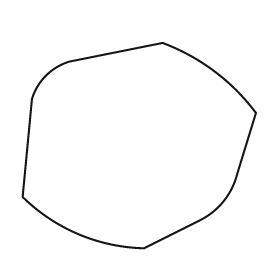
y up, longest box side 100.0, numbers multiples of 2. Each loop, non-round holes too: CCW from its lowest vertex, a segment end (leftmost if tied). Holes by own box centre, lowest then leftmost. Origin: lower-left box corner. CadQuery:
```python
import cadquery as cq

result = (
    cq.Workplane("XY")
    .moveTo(52.0, 0.0)
    .lineTo(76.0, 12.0)
    .threePointArc((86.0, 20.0), (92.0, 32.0))
    .lineTo(100.0, 58.0)
    .threePointArc((82.0, 76.0), (60.0, 88.0))
    .lineTo(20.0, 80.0)
    .threePointArc((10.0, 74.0), (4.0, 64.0))
    .lineTo(0.0, 22.0)
    .threePointArc((24.0, 6.0), (52.0, 0.0))
    .close()
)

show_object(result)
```